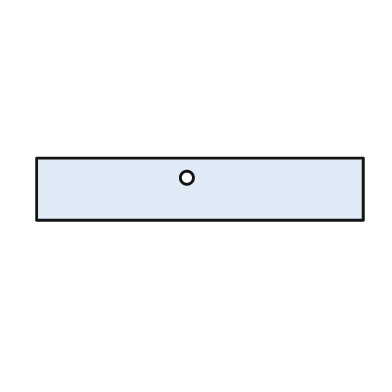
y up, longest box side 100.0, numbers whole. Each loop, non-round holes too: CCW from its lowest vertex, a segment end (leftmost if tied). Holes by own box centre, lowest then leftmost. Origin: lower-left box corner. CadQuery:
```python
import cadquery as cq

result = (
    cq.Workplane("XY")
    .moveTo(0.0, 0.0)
    .lineTo(100.0, 0.0)
    .lineTo(100.0, 19.0)
    .lineTo(0.0, 19.0)
    .close()
    .moveTo(46.0, 13.0)
    .circle(2.0)
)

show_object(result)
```